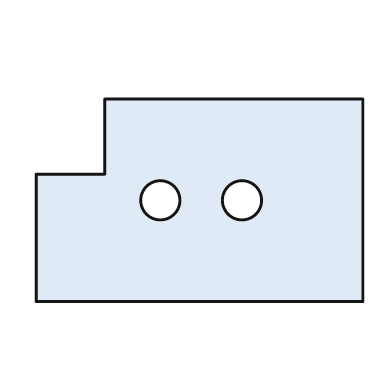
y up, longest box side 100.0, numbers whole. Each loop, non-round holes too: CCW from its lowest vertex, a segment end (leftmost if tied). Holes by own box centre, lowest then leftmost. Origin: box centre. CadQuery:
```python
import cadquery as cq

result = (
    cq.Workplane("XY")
    .moveTo(-50.0, -31.0)
    .lineTo(50.0, -31.0)
    .lineTo(50.0, 31.0)
    .lineTo(-29.0, 31.0)
    .lineTo(-29.0, 8.0)
    .lineTo(-50.0, 8.0)
    .close()
    .moveTo(-12.0, 0.0)
    .circle(6.0)
    .moveTo(13.0, 0.0)
    .circle(6.0)
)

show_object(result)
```